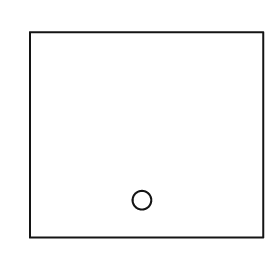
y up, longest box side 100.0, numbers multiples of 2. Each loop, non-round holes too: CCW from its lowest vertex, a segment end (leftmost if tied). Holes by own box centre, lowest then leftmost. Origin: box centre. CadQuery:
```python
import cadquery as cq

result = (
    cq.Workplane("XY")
    .moveTo(-50.0, -44.0)
    .lineTo(50.0, -44.0)
    .lineTo(50.0, 44.0)
    .lineTo(-50.0, 44.0)
    .close()
    .moveTo(-2.0, -28.0)
    .circle(4.0)
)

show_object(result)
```